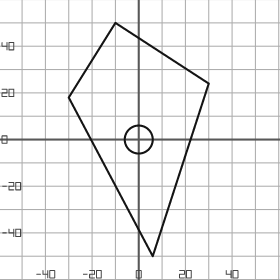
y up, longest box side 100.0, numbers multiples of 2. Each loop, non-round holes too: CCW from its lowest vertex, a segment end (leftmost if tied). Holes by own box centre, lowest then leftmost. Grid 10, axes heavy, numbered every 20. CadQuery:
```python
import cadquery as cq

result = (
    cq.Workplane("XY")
    .moveTo(6.0, -50.0)
    .lineTo(30.0, 24.0)
    .lineTo(-10.0, 50.0)
    .lineTo(-30.0, 18.0)
    .close()
    .moveTo(0.0, 0.0)
    .circle(6.0)
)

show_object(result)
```